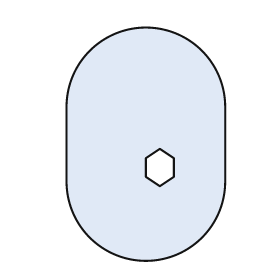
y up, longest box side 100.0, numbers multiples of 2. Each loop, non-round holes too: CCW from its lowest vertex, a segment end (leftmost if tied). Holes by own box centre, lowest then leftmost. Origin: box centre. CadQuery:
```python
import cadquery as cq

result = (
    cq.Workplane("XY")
    .moveTo(-34.0, -16.0)
    .threePointArc((0.0, -50.0), (34.0, -16.0))
    .lineTo(34.0, 16.0)
    .threePointArc((0.0, 50.0), (-34.0, 16.0))
    .close()
    .moveTo(6.0, -18.0)
    .lineTo(12.0, -14.0)
    .lineTo(12.0, -6.0)
    .lineTo(6.0, -2.0)
    .lineTo(0.0, -6.0)
    .lineTo(0.0, -14.0)
    .close()
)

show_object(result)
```